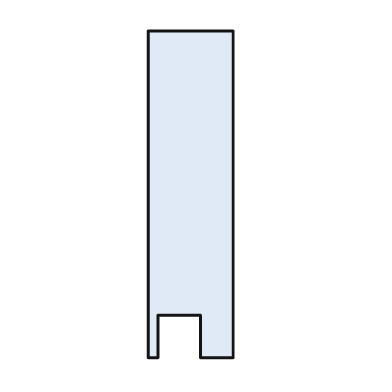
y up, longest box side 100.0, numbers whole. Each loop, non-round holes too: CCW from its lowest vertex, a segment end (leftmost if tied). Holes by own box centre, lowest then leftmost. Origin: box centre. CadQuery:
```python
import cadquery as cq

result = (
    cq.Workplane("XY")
    .moveTo(-13.0, -50.0)
    .lineTo(-10.0, -50.0)
    .lineTo(-10.0, -37.0)
    .lineTo(3.0, -37.0)
    .lineTo(3.0, -50.0)
    .lineTo(13.0, -50.0)
    .lineTo(13.0, 50.0)
    .lineTo(-13.0, 50.0)
    .close()
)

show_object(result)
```